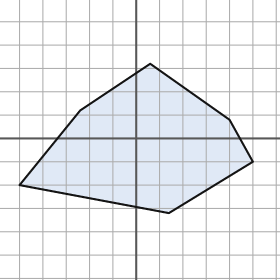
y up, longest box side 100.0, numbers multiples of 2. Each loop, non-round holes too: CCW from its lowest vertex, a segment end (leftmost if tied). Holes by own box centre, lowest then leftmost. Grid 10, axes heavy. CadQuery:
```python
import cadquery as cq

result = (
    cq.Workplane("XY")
    .moveTo(14.0, -32.0)
    .lineTo(50.0, -10.0)
    .lineTo(40.0, 8.0)
    .lineTo(6.0, 32.0)
    .lineTo(-24.0, 12.0)
    .lineTo(-50.0, -20.0)
    .close()
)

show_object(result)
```